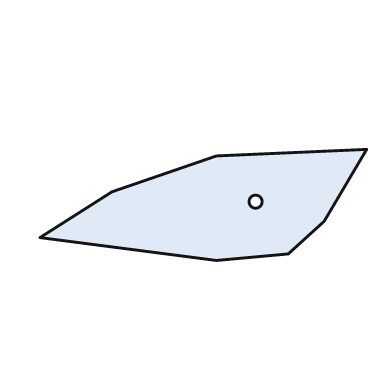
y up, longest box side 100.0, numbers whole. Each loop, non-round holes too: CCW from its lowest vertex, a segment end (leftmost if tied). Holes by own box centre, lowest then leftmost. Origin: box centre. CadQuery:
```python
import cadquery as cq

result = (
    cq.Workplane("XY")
    .moveTo(4.0, -17.0)
    .lineTo(26.0, -15.0)
    .lineTo(37.0, -5.0)
    .lineTo(50.0, 17.0)
    .lineTo(4.0, 15.0)
    .lineTo(-28.0, 4.0)
    .lineTo(-50.0, -10.0)
    .close()
    .moveTo(16.0, 1.0)
    .circle(2.0)
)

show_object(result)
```